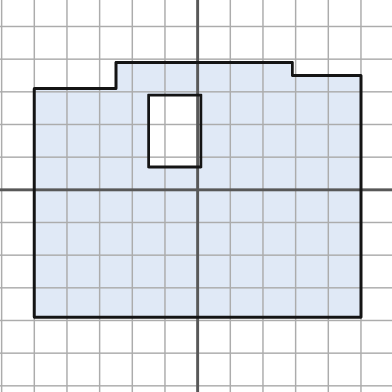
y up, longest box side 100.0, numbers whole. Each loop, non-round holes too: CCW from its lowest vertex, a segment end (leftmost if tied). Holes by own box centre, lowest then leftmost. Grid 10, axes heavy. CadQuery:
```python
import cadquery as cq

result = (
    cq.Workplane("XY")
    .moveTo(-50.0, -39.0)
    .lineTo(50.0, -39.0)
    .lineTo(50.0, 35.0)
    .lineTo(29.0, 35.0)
    .lineTo(29.0, 39.0)
    .lineTo(-25.0, 39.0)
    .lineTo(-25.0, 31.0)
    .lineTo(-50.0, 31.0)
    .close()
    .moveTo(-15.0, 7.0)
    .lineTo(1.0, 7.0)
    .lineTo(1.0, 29.0)
    .lineTo(-15.0, 29.0)
    .close()
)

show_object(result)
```